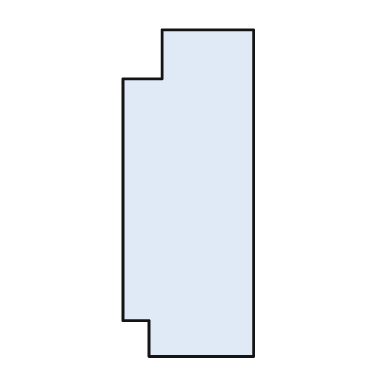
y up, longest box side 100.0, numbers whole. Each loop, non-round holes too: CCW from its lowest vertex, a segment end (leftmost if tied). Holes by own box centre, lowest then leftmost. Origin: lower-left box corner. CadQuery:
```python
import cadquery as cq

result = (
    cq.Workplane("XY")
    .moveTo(8.0, 0.0)
    .lineTo(40.0, 0.0)
    .lineTo(40.0, 100.0)
    .lineTo(12.0, 100.0)
    .lineTo(12.0, 85.0)
    .lineTo(0.0, 85.0)
    .lineTo(0.0, 11.0)
    .lineTo(8.0, 11.0)
    .close()
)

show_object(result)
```